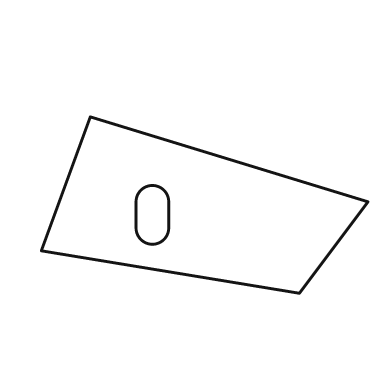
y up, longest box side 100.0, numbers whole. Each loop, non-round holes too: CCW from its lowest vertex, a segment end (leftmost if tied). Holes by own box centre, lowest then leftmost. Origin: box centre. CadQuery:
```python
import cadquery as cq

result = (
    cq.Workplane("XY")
    .moveTo(29.0, -27.0)
    .lineTo(50.0, 1.0)
    .lineTo(-35.0, 27.0)
    .lineTo(-50.0, -14.0)
    .close()
    .moveTo(-21.0, -7.0)
    .threePointArc((-16.0, -12.0), (-11.0, -7.0))
    .lineTo(-11.0, 1.0)
    .threePointArc((-16.0, 6.0), (-21.0, 1.0))
    .close()
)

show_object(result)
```